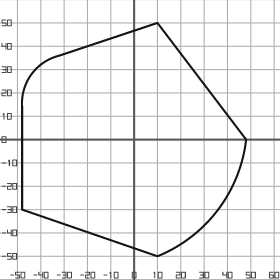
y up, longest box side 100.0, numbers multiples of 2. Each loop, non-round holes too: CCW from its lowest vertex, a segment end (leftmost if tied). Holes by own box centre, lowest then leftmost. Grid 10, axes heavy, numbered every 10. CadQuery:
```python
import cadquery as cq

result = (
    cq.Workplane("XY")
    .moveTo(10.0, -50.0)
    .threePointArc((36.0, -30.0), (48.0, 0.0))
    .lineTo(10.0, 50.0)
    .lineTo(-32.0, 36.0)
    .threePointArc((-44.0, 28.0), (-48.0, 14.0))
    .lineTo(-48.0, -30.0)
    .close()
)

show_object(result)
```